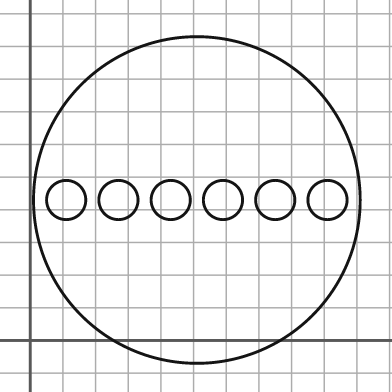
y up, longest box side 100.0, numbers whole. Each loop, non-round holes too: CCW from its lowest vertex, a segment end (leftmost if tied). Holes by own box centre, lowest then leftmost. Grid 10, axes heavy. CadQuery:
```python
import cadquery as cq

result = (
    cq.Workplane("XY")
    .moveTo(51.0, 43.0)
    .circle(50.0)
    .moveTo(11.0, 43.0)
    .circle(6.0)
    .moveTo(27.0, 43.0)
    .circle(6.0)
    .moveTo(43.0, 43.0)
    .circle(6.0)
    .moveTo(59.0, 43.0)
    .circle(6.0)
    .moveTo(75.0, 43.0)
    .circle(6.0)
    .moveTo(91.0, 43.0)
    .circle(6.0)
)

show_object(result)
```